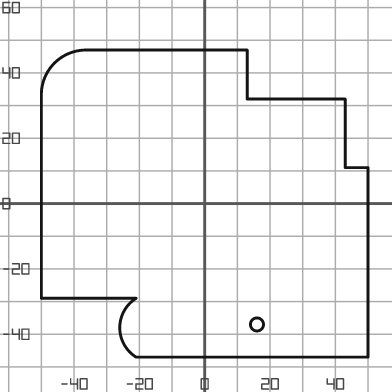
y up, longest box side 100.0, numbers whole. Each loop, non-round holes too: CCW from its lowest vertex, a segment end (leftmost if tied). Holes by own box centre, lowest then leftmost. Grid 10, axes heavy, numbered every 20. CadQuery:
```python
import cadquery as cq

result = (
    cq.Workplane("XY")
    .moveTo(-21.0, -47.0)
    .lineTo(50.0, -47.0)
    .lineTo(50.0, 11.0)
    .lineTo(43.0, 11.0)
    .lineTo(43.0, 32.0)
    .lineTo(13.0, 32.0)
    .lineTo(13.0, 47.0)
    .lineTo(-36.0, 47.0)
    .threePointArc((-46.0, 43.0), (-50.0, 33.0))
    .lineTo(-50.0, -29.0)
    .lineTo(-21.0, -29.0)
    .threePointArc((-26.0, -38.0), (-21.0, -47.0))
    .close()
    .moveTo(16.0, -37.0)
    .circle(2.0)
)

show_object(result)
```